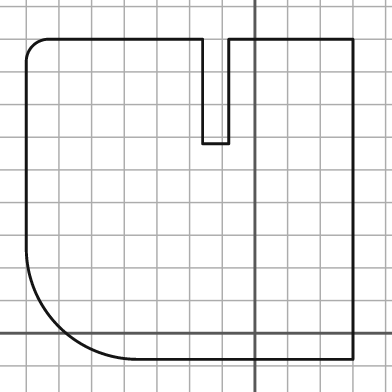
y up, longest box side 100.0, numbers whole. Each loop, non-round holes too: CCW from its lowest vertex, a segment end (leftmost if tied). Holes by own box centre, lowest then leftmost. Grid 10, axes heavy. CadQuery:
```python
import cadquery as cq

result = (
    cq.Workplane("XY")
    .moveTo(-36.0, -8.0)
    .lineTo(30.0, -8.0)
    .lineTo(30.0, 90.0)
    .lineTo(-8.0, 90.0)
    .lineTo(-8.0, 58.0)
    .lineTo(-16.0, 58.0)
    .lineTo(-16.0, 90.0)
    .lineTo(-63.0, 90.0)
    .threePointArc((-68.0, 88.0), (-70.0, 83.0))
    .lineTo(-70.0, 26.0)
    .threePointArc((-60.0, 2.0), (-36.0, -8.0))
    .close()
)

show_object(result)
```